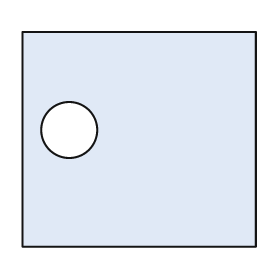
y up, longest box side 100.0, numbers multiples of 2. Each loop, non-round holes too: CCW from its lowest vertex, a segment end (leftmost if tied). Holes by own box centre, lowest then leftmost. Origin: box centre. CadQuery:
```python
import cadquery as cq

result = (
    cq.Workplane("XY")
    .moveTo(-50.0, -46.0)
    .lineTo(50.0, -46.0)
    .lineTo(50.0, 46.0)
    .lineTo(-50.0, 46.0)
    .close()
    .moveTo(-30.0, 4.0)
    .circle(12.0)
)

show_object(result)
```